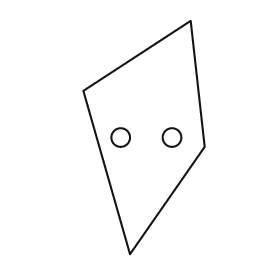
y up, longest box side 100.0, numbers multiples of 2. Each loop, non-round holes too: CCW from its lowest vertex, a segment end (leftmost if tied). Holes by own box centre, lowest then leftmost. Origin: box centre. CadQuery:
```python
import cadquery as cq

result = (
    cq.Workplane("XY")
    .moveTo(-6.0, -50.0)
    .lineTo(26.0, -4.0)
    .lineTo(20.0, 50.0)
    .lineTo(-26.0, 20.0)
    .close()
    .moveTo(-10.0, 0.0)
    .circle(4.0)
    .moveTo(12.0, 0.0)
    .circle(4.0)
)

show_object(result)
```